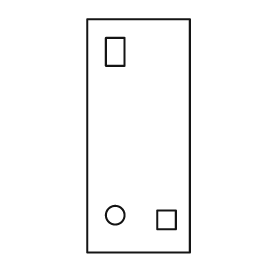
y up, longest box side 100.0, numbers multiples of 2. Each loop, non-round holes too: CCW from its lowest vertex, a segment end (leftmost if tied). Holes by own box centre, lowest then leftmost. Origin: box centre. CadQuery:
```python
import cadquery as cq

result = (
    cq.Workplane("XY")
    .moveTo(-22.0, -50.0)
    .lineTo(22.0, -50.0)
    .lineTo(22.0, 50.0)
    .lineTo(-22.0, 50.0)
    .close()
    .moveTo(8.0, -40.0)
    .lineTo(16.0, -40.0)
    .lineTo(16.0, -32.0)
    .lineTo(8.0, -32.0)
    .close()
    .moveTo(-10.0, -34.0)
    .circle(4.0)
    .moveTo(-14.0, 30.0)
    .lineTo(-6.0, 30.0)
    .lineTo(-6.0, 42.0)
    .lineTo(-14.0, 42.0)
    .close()
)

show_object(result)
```